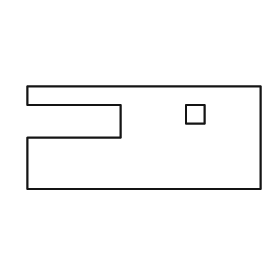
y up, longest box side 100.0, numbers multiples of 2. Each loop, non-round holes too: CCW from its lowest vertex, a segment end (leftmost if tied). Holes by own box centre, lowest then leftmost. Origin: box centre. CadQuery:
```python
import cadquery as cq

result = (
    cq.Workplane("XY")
    .moveTo(-50.0, -22.0)
    .lineTo(50.0, -22.0)
    .lineTo(50.0, 22.0)
    .lineTo(-50.0, 22.0)
    .lineTo(-50.0, 14.0)
    .lineTo(-10.0, 14.0)
    .lineTo(-10.0, 0.0)
    .lineTo(-50.0, 0.0)
    .close()
    .moveTo(18.0, 6.0)
    .lineTo(26.0, 6.0)
    .lineTo(26.0, 14.0)
    .lineTo(18.0, 14.0)
    .close()
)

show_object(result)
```